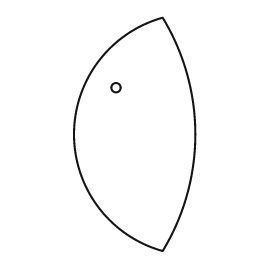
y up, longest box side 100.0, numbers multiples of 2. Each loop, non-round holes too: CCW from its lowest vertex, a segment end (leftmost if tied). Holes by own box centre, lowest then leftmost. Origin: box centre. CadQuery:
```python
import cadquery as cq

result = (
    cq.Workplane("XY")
    .moveTo(12.0, -50.0)
    .threePointArc((26.0, 0.0), (12.0, 50.0))
    .threePointArc((-26.0, 0.0), (12.0, -50.0))
    .close()
    .moveTo(-8.0, 20.0)
    .circle(2.0)
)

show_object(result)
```